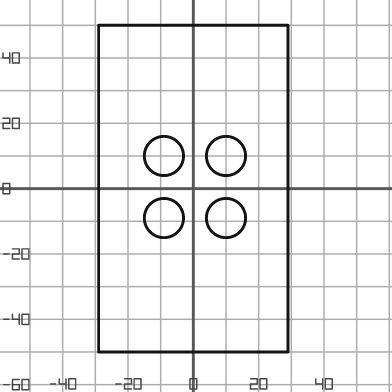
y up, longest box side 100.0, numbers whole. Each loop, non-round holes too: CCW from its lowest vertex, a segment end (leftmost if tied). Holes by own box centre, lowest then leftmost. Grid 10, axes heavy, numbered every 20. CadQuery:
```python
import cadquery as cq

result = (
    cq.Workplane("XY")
    .moveTo(-29.0, -50.0)
    .lineTo(29.0, -50.0)
    .lineTo(29.0, 50.0)
    .lineTo(-29.0, 50.0)
    .close()
    .moveTo(-9.0, -9.0)
    .circle(6.0)
    .moveTo(10.0, -9.0)
    .circle(6.0)
    .moveTo(-9.0, 10.0)
    .circle(6.0)
    .moveTo(10.0, 10.0)
    .circle(6.0)
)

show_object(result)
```